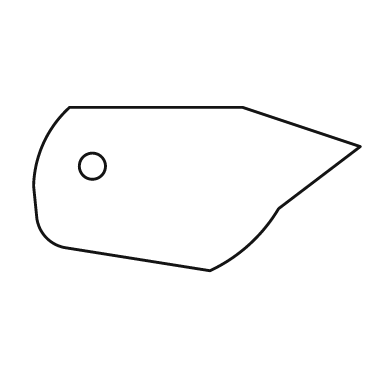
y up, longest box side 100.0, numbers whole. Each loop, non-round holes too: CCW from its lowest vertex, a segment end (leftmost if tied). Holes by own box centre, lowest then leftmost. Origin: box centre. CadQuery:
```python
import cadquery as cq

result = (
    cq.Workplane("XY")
    .moveTo(4.0, -25.0)
    .threePointArc((16.0, -17.0), (25.0, -6.0))
    .lineTo(50.0, 13.0)
    .lineTo(14.0, 25.0)
    .lineTo(-39.0, 25.0)
    .threePointArc((-47.0, 14.0), (-50.0, 1.0))
    .lineTo(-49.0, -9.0)
    .threePointArc((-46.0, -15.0), (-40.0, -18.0))
    .close()
    .moveTo(-32.0, 7.0)
    .circle(4.0)
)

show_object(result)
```